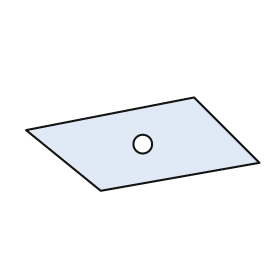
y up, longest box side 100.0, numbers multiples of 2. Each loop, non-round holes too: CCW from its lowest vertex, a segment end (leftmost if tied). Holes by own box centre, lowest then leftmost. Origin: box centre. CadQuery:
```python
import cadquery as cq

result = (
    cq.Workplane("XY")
    .moveTo(-18.0, -20.0)
    .lineTo(50.0, -8.0)
    .lineTo(22.0, 20.0)
    .lineTo(-50.0, 6.0)
    .close()
    .moveTo(0.0, 0.0)
    .circle(4.0)
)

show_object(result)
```